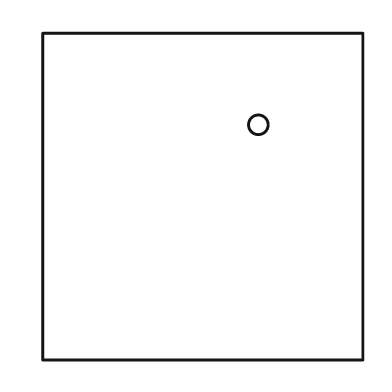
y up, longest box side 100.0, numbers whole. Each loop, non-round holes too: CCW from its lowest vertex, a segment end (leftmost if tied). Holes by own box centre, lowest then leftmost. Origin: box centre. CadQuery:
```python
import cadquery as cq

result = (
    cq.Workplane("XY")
    .moveTo(-49.0, -50.0)
    .lineTo(49.0, -50.0)
    .lineTo(49.0, 50.0)
    .lineTo(-49.0, 50.0)
    .close()
    .moveTo(17.0, 22.0)
    .circle(3.0)
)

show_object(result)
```